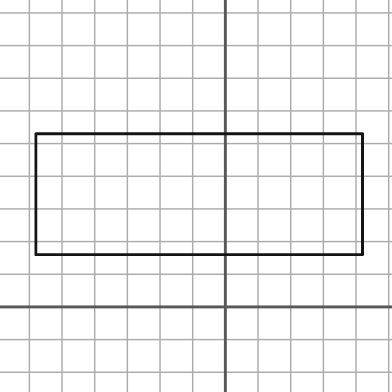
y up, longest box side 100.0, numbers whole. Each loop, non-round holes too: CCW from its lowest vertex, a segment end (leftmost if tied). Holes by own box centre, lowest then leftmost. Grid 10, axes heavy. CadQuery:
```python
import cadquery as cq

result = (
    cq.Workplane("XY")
    .moveTo(-58.0, 16.0)
    .lineTo(42.0, 16.0)
    .lineTo(42.0, 53.0)
    .lineTo(-58.0, 53.0)
    .close()
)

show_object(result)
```